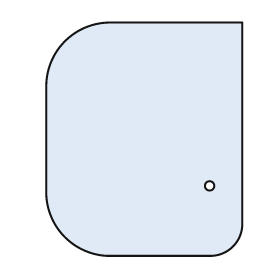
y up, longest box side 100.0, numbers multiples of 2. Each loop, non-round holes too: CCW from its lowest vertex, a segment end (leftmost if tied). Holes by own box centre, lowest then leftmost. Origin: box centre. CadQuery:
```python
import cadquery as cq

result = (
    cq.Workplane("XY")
    .moveTo(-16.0, -50.0)
    .lineTo(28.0, -50.0)
    .threePointArc((38.0, -46.0), (42.0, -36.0))
    .lineTo(42.0, 50.0)
    .lineTo(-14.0, 50.0)
    .threePointArc((-34.0, 42.0), (-42.0, 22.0))
    .lineTo(-42.0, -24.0)
    .threePointArc((-34.0, -42.0), (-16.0, -50.0))
    .close()
    .moveTo(28.0, -20.0)
    .circle(2.0)
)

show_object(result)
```